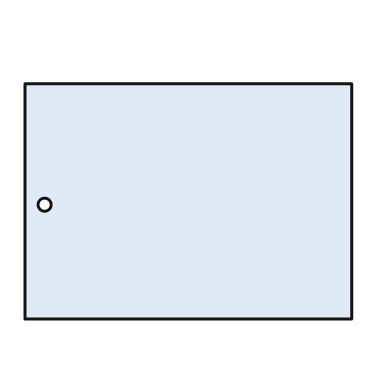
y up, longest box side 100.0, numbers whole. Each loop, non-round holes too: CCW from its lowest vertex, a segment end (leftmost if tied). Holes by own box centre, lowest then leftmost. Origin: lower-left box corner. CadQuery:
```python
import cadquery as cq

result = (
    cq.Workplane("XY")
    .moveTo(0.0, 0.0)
    .lineTo(100.0, 0.0)
    .lineTo(100.0, 72.0)
    .lineTo(0.0, 72.0)
    .close()
    .moveTo(6.0, 35.0)
    .circle(2.0)
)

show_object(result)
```